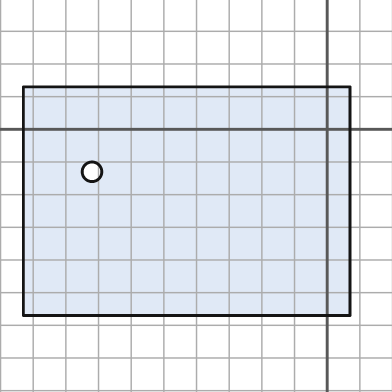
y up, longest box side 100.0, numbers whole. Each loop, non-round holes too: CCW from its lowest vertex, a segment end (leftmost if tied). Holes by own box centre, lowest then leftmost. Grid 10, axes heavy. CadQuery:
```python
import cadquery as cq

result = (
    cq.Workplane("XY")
    .moveTo(-93.0, -57.0)
    .lineTo(7.0, -57.0)
    .lineTo(7.0, 13.0)
    .lineTo(-93.0, 13.0)
    .close()
    .moveTo(-72.0, -13.0)
    .circle(3.0)
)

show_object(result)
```